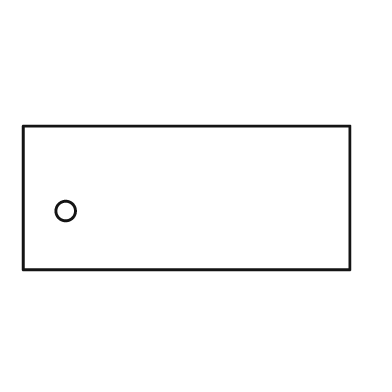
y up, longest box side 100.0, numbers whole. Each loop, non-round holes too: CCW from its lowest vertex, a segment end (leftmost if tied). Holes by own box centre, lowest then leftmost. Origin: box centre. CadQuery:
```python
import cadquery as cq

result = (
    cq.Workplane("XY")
    .moveTo(-50.0, -22.0)
    .lineTo(50.0, -22.0)
    .lineTo(50.0, 22.0)
    .lineTo(-50.0, 22.0)
    .close()
    .moveTo(-37.0, -4.0)
    .circle(3.0)
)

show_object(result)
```